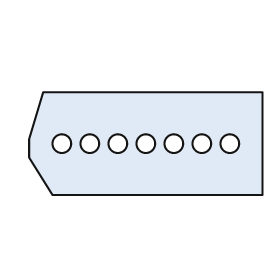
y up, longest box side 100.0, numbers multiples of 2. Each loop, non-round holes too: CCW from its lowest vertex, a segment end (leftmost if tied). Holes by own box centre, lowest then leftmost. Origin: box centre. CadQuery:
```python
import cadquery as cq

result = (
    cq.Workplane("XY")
    .moveTo(-40.0, -22.0)
    .lineTo(50.0, -22.0)
    .lineTo(50.0, 22.0)
    .lineTo(-44.0, 22.0)
    .lineTo(-50.0, 2.0)
    .lineTo(-50.0, -6.0)
    .close()
    .moveTo(-36.0, 0.0)
    .circle(4.0)
    .moveTo(-24.0, 0.0)
    .circle(4.0)
    .moveTo(-12.0, 0.0)
    .circle(4.0)
    .moveTo(0.0, 0.0)
    .circle(4.0)
    .moveTo(12.0, 0.0)
    .circle(4.0)
    .moveTo(24.0, 0.0)
    .circle(4.0)
    .moveTo(36.0, 0.0)
    .circle(4.0)
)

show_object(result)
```